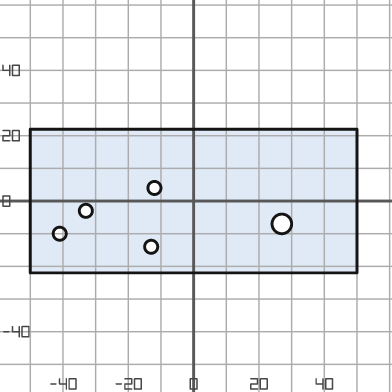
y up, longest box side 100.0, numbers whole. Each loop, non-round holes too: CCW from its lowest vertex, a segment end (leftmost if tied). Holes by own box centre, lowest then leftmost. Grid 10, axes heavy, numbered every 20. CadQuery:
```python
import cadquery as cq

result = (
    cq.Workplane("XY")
    .moveTo(-50.0, -22.0)
    .lineTo(50.0, -22.0)
    .lineTo(50.0, 22.0)
    .lineTo(-50.0, 22.0)
    .close()
    .moveTo(-13.0, -14.0)
    .circle(2.0)
    .moveTo(-41.0, -10.0)
    .circle(2.0)
    .moveTo(27.0, -7.0)
    .circle(3.0)
    .moveTo(-33.0, -3.0)
    .circle(2.0)
    .moveTo(-12.0, 4.0)
    .circle(2.0)
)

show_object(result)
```